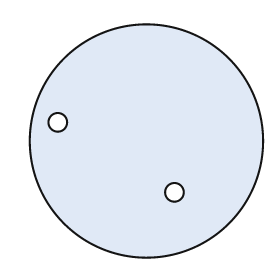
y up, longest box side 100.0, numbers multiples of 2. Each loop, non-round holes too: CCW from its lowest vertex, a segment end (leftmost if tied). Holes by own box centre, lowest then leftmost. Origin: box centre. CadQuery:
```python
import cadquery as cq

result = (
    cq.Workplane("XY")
    .moveTo(0.0, 0.0)
    .circle(50.0)
    .moveTo(12.0, -22.0)
    .circle(4.0)
    .moveTo(-38.0, 8.0)
    .circle(4.0)
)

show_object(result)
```